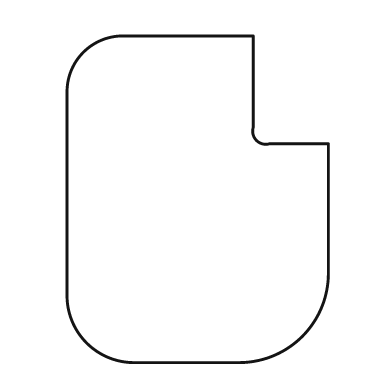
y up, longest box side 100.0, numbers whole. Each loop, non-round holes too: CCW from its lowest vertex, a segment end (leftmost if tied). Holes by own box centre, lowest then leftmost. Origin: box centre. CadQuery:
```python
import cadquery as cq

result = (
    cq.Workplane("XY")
    .moveTo(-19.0, -50.0)
    .lineTo(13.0, -50.0)
    .threePointArc((32.0, -42.0), (40.0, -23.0))
    .lineTo(40.0, 17.0)
    .lineTo(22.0, 17.0)
    .threePointArc((18.0, 18.0), (17.0, 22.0))
    .lineTo(17.0, 50.0)
    .lineTo(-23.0, 50.0)
    .threePointArc((-35.0, 45.0), (-40.0, 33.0))
    .lineTo(-40.0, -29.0)
    .threePointArc((-34.0, -44.0), (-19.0, -50.0))
    .close()
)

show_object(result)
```